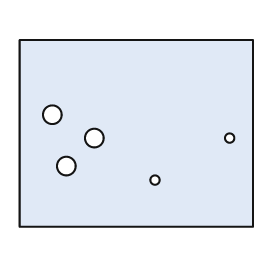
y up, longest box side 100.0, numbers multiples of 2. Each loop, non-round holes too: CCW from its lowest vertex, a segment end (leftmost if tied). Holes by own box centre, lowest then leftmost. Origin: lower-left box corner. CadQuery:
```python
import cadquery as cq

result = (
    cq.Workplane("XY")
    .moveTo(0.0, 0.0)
    .lineTo(100.0, 0.0)
    .lineTo(100.0, 80.0)
    .lineTo(0.0, 80.0)
    .close()
    .moveTo(58.0, 20.0)
    .circle(2.0)
    .moveTo(20.0, 26.0)
    .circle(4.0)
    .moveTo(32.0, 38.0)
    .circle(4.0)
    .moveTo(90.0, 38.0)
    .circle(2.0)
    .moveTo(14.0, 48.0)
    .circle(4.0)
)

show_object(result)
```